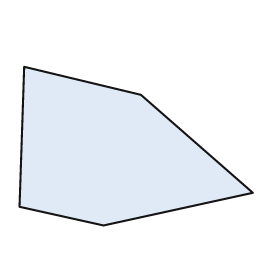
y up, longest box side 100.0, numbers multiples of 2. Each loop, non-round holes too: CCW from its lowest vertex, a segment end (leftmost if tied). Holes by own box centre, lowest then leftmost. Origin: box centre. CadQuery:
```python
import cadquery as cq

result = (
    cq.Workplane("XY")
    .moveTo(-14.0, -34.0)
    .lineTo(50.0, -20.0)
    .lineTo(2.0, 22.0)
    .lineTo(-48.0, 34.0)
    .lineTo(-50.0, -26.0)
    .close()
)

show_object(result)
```